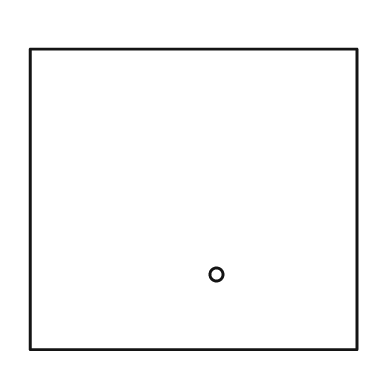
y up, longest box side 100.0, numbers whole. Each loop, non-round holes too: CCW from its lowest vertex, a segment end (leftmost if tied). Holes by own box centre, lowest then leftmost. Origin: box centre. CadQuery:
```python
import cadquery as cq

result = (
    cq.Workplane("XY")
    .moveTo(-50.0, -46.0)
    .lineTo(50.0, -46.0)
    .lineTo(50.0, 46.0)
    .lineTo(-50.0, 46.0)
    .close()
    .moveTo(7.0, -23.0)
    .circle(2.0)
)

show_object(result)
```